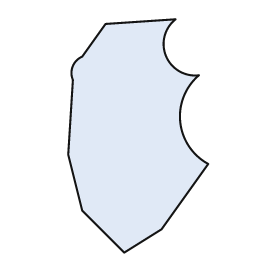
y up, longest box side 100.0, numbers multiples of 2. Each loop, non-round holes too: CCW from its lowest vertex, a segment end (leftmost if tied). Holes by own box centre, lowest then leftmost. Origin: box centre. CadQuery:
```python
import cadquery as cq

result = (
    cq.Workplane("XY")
    .moveTo(-6.0, -50.0)
    .lineTo(10.0, -40.0)
    .lineTo(30.0, -12.0)
    .threePointArc((18.0, 6.0), (26.0, 26.0))
    .threePointArc((12.0, 34.0), (16.0, 50.0))
    .lineTo(-14.0, 48.0)
    .lineTo(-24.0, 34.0)
    .threePointArc((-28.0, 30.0), (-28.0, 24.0))
    .lineTo(-30.0, -8.0)
    .lineTo(-24.0, -32.0)
    .close()
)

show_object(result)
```